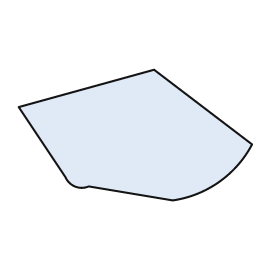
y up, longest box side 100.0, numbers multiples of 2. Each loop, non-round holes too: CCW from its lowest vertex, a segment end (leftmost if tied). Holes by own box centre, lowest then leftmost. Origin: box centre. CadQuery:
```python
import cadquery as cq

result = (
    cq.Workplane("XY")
    .moveTo(16.0, -28.0)
    .threePointArc((36.0, -20.0), (50.0, -4.0))
    .lineTo(8.0, 28.0)
    .lineTo(-50.0, 12.0)
    .lineTo(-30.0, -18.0)
    .threePointArc((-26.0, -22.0), (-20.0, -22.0))
    .close()
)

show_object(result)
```